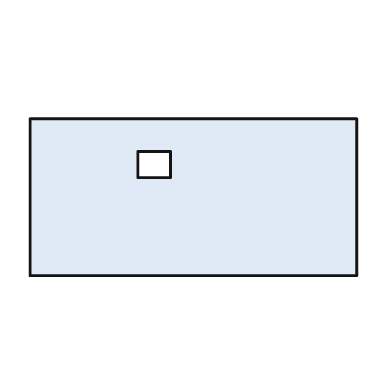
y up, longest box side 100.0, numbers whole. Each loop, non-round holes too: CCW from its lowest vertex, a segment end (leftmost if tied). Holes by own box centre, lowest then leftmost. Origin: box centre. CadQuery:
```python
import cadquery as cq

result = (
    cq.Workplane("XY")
    .moveTo(-50.0, -24.0)
    .lineTo(50.0, -24.0)
    .lineTo(50.0, 24.0)
    .lineTo(-50.0, 24.0)
    .close()
    .moveTo(-17.0, 6.0)
    .lineTo(-7.0, 6.0)
    .lineTo(-7.0, 14.0)
    .lineTo(-17.0, 14.0)
    .close()
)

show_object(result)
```